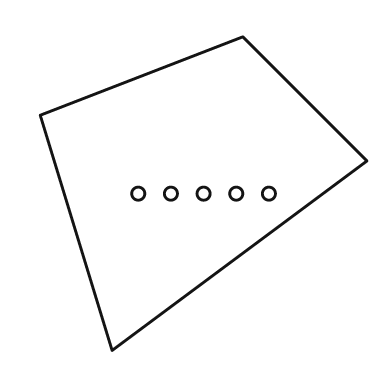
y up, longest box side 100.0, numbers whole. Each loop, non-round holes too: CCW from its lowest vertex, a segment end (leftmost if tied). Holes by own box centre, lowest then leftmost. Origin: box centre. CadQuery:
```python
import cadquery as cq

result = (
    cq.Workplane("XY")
    .moveTo(-28.0, -48.0)
    .lineTo(50.0, 10.0)
    .lineTo(12.0, 48.0)
    .lineTo(-50.0, 24.0)
    .close()
    .moveTo(-20.0, 0.0)
    .circle(2.0)
    .moveTo(-10.0, 0.0)
    .circle(2.0)
    .moveTo(0.0, 0.0)
    .circle(2.0)
    .moveTo(10.0, 0.0)
    .circle(2.0)
    .moveTo(20.0, 0.0)
    .circle(2.0)
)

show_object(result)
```